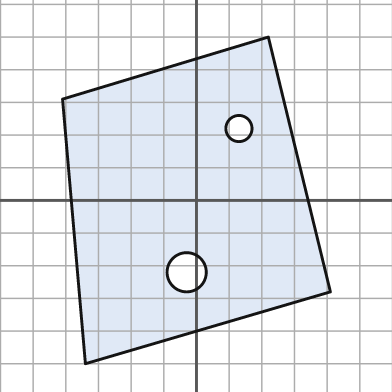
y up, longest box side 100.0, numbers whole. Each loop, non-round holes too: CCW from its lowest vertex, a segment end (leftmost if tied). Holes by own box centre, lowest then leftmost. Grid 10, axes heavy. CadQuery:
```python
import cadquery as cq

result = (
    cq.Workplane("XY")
    .moveTo(-34.0, -50.0)
    .lineTo(41.0, -28.0)
    .lineTo(22.0, 50.0)
    .lineTo(-41.0, 31.0)
    .close()
    .moveTo(-3.0, -22.0)
    .circle(6.0)
    .moveTo(13.0, 22.0)
    .circle(4.0)
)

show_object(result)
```